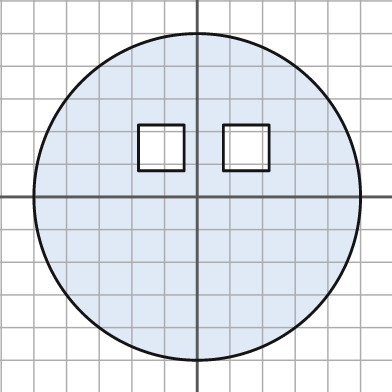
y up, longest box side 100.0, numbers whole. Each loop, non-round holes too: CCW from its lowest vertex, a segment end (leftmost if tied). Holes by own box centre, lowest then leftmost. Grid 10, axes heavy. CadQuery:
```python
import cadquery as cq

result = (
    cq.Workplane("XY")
    .moveTo(0.0, 0.0)
    .circle(50.0)
    .moveTo(-18.0, 8.0)
    .lineTo(-4.0, 8.0)
    .lineTo(-4.0, 22.0)
    .lineTo(-18.0, 22.0)
    .close()
    .moveTo(8.0, 8.0)
    .lineTo(22.0, 8.0)
    .lineTo(22.0, 22.0)
    .lineTo(8.0, 22.0)
    .close()
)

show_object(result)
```